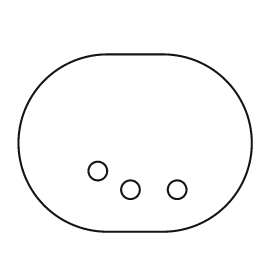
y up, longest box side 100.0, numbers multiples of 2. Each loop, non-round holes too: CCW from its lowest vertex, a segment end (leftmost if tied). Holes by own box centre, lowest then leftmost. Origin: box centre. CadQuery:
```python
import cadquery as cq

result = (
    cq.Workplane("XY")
    .moveTo(-12.0, -38.0)
    .lineTo(12.0, -38.0)
    .threePointArc((50.0, 0.0), (12.0, 38.0))
    .lineTo(-12.0, 38.0)
    .threePointArc((-50.0, 0.0), (-12.0, -38.0))
    .close()
    .moveTo(-2.0, -20.0)
    .circle(4.0)
    .moveTo(18.0, -20.0)
    .circle(4.0)
    .moveTo(-16.0, -12.0)
    .circle(4.0)
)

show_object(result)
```